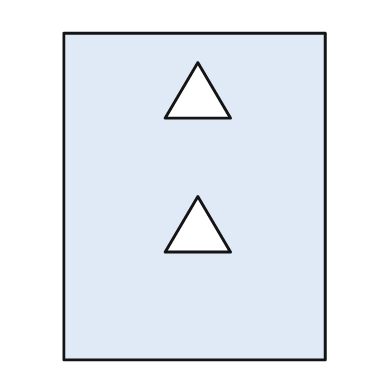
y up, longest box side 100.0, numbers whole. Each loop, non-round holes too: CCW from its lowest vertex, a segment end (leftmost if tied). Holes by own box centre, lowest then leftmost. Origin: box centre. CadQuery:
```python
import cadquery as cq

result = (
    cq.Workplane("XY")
    .moveTo(-40.0, -50.0)
    .lineTo(40.0, -50.0)
    .lineTo(40.0, 50.0)
    .lineTo(-40.0, 50.0)
    .close()
    .moveTo(-9.0, -17.0)
    .lineTo(11.0, -17.0)
    .lineTo(1.0, 0.0)
    .close()
    .moveTo(-9.0, 24.0)
    .lineTo(11.0, 24.0)
    .lineTo(1.0, 41.0)
    .close()
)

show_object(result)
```